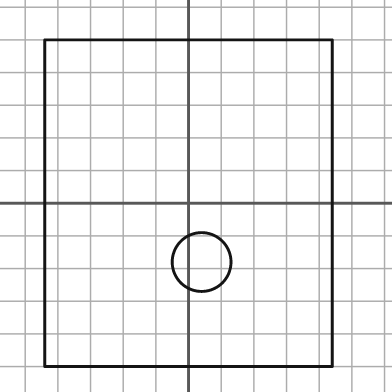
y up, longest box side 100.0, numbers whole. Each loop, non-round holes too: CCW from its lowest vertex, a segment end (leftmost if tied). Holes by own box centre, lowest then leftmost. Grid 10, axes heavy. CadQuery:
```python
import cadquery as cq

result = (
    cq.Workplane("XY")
    .moveTo(-44.0, -50.0)
    .lineTo(44.0, -50.0)
    .lineTo(44.0, 50.0)
    .lineTo(-44.0, 50.0)
    .close()
    .moveTo(4.0, -18.0)
    .circle(9.0)
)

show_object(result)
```